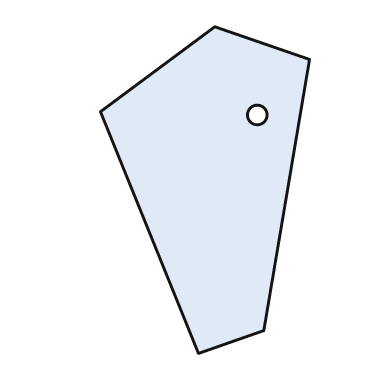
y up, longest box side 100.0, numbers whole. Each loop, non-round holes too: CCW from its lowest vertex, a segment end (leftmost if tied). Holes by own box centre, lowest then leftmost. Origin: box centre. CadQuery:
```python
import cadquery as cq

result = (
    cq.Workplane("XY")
    .moveTo(-2.0, -50.0)
    .lineTo(18.0, -43.0)
    .lineTo(32.0, 40.0)
    .lineTo(3.0, 50.0)
    .lineTo(-32.0, 24.0)
    .close()
    .moveTo(16.0, 23.0)
    .circle(3.0)
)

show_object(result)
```